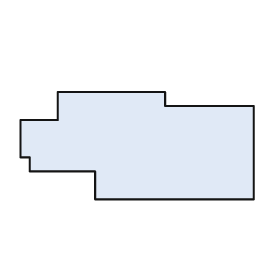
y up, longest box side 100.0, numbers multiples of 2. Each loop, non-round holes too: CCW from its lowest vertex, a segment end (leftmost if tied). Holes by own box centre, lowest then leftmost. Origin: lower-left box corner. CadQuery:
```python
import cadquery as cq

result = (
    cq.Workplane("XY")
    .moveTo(32.0, 0.0)
    .lineTo(100.0, 0.0)
    .lineTo(100.0, 40.0)
    .lineTo(62.0, 40.0)
    .lineTo(62.0, 46.0)
    .lineTo(16.0, 46.0)
    .lineTo(16.0, 34.0)
    .lineTo(0.0, 34.0)
    .lineTo(0.0, 18.0)
    .lineTo(4.0, 18.0)
    .lineTo(4.0, 12.0)
    .lineTo(32.0, 12.0)
    .close()
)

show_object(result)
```